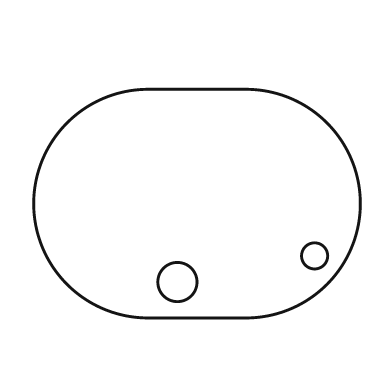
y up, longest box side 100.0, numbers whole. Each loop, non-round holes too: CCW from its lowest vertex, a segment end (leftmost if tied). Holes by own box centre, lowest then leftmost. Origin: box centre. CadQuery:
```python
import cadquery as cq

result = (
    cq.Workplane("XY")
    .moveTo(-15.0, -35.0)
    .lineTo(15.0, -35.0)
    .threePointArc((50.0, 0.0), (15.0, 35.0))
    .lineTo(-15.0, 35.0)
    .threePointArc((-50.0, 0.0), (-15.0, -35.0))
    .close()
    .moveTo(-6.0, -24.0)
    .circle(6.0)
    .moveTo(36.0, -16.0)
    .circle(4.0)
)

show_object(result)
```